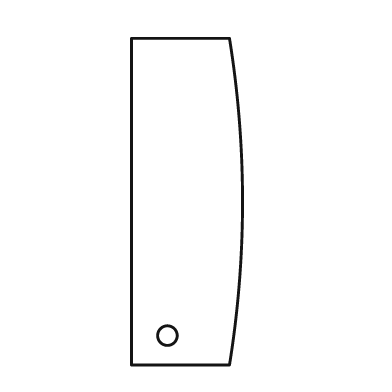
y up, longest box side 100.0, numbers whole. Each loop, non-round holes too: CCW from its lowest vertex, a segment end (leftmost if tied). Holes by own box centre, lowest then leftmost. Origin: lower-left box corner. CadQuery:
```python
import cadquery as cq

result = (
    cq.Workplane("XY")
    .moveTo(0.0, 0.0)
    .lineTo(30.0, 0.0)
    .threePointArc((34.0, 50.0), (30.0, 100.0))
    .lineTo(0.0, 100.0)
    .close()
    .moveTo(11.0, 9.0)
    .circle(3.0)
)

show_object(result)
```